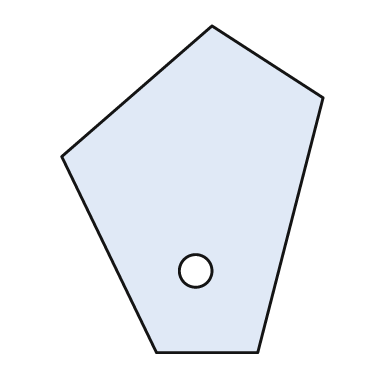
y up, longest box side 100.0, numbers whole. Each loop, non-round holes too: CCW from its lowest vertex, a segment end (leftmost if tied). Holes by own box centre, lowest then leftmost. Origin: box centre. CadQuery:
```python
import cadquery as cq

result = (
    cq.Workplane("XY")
    .moveTo(-11.0, -50.0)
    .lineTo(20.0, -50.0)
    .lineTo(40.0, 28.0)
    .lineTo(6.0, 50.0)
    .lineTo(-40.0, 10.0)
    .close()
    .moveTo(1.0, -25.0)
    .circle(5.0)
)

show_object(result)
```